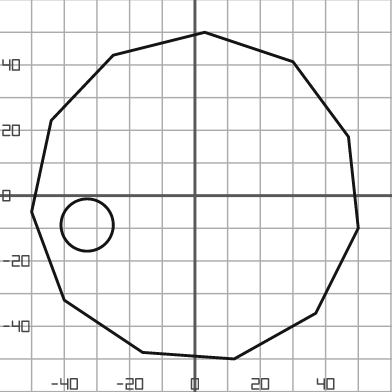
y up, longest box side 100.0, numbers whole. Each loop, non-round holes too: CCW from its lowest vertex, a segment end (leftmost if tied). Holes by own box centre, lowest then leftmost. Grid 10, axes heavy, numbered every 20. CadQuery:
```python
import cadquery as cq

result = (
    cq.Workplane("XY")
    .moveTo(12.0, -50.0)
    .lineTo(37.0, -36.0)
    .lineTo(50.0, -10.0)
    .lineTo(47.0, 18.0)
    .lineTo(30.0, 41.0)
    .lineTo(3.0, 50.0)
    .lineTo(-25.0, 43.0)
    .lineTo(-44.0, 23.0)
    .lineTo(-50.0, -5.0)
    .lineTo(-40.0, -32.0)
    .lineTo(-16.0, -48.0)
    .close()
    .moveTo(-33.0, -9.0)
    .circle(8.0)
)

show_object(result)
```